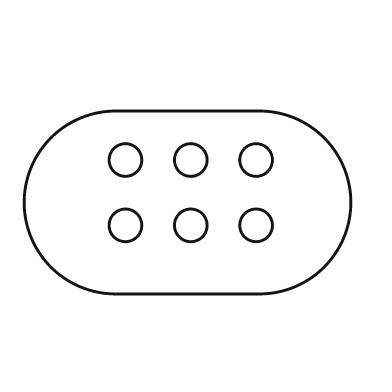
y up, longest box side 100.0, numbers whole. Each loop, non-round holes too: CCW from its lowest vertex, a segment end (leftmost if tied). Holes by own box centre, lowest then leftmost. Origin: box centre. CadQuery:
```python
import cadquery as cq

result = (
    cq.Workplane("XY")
    .moveTo(-22.0, -28.0)
    .lineTo(22.0, -28.0)
    .threePointArc((50.0, 0.0), (22.0, 28.0))
    .lineTo(-22.0, 28.0)
    .threePointArc((-50.0, 0.0), (-22.0, -28.0))
    .close()
    .moveTo(-19.0, -7.0)
    .circle(5.0)
    .moveTo(1.0, -7.0)
    .circle(5.0)
    .moveTo(21.0, -7.0)
    .circle(5.0)
    .moveTo(-19.0, 13.0)
    .circle(5.0)
    .moveTo(1.0, 13.0)
    .circle(5.0)
    .moveTo(21.0, 13.0)
    .circle(5.0)
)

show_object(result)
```